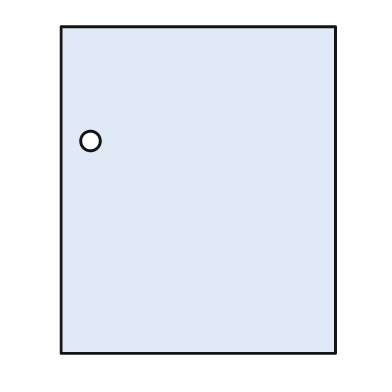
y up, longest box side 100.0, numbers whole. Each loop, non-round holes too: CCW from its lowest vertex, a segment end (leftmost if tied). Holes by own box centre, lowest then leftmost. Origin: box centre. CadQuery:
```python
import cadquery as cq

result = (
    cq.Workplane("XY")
    .moveTo(-42.0, -50.0)
    .lineTo(42.0, -50.0)
    .lineTo(42.0, 50.0)
    .lineTo(-42.0, 50.0)
    .close()
    .moveTo(-33.0, 15.0)
    .circle(3.0)
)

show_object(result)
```